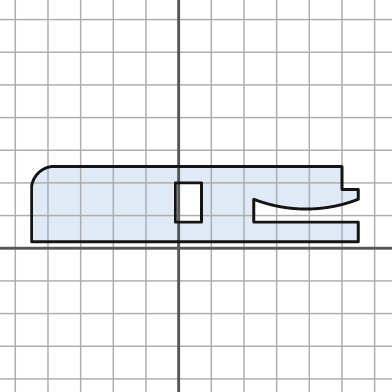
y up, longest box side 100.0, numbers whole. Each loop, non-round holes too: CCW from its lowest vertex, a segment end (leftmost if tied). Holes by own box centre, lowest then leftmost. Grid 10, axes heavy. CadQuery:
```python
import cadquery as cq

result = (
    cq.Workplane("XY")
    .moveTo(-45.0, 2.0)
    .lineTo(55.0, 2.0)
    .lineTo(55.0, 8.0)
    .lineTo(23.0, 8.0)
    .lineTo(23.0, 15.0)
    .threePointArc((39.0, 12.0), (55.0, 15.0))
    .lineTo(55.0, 18.0)
    .lineTo(50.0, 18.0)
    .lineTo(50.0, 25.0)
    .lineTo(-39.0, 25.0)
    .threePointArc((-43.0, 23.0), (-45.0, 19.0))
    .close()
    .moveTo(-1.0, 8.0)
    .lineTo(7.0, 8.0)
    .lineTo(7.0, 20.0)
    .lineTo(-1.0, 20.0)
    .close()
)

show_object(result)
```